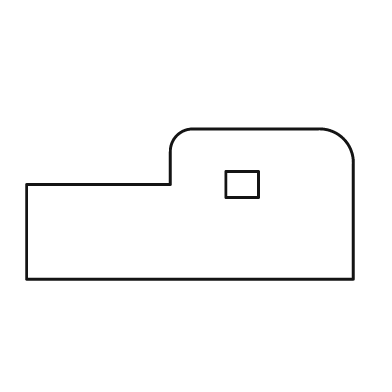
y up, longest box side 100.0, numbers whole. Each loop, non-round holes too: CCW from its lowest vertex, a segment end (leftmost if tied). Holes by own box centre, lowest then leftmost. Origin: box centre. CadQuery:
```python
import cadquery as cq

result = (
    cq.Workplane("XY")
    .moveTo(-50.0, -23.0)
    .lineTo(50.0, -23.0)
    .lineTo(50.0, 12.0)
    .threePointArc((47.0, 20.0), (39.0, 23.0))
    .lineTo(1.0, 23.0)
    .threePointArc((-4.0, 21.0), (-6.0, 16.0))
    .lineTo(-6.0, 6.0)
    .lineTo(-50.0, 6.0)
    .close()
    .moveTo(11.0, 2.0)
    .lineTo(21.0, 2.0)
    .lineTo(21.0, 10.0)
    .lineTo(11.0, 10.0)
    .close()
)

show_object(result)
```